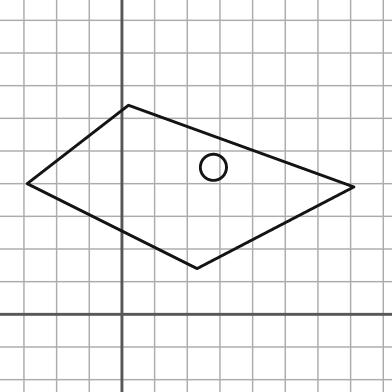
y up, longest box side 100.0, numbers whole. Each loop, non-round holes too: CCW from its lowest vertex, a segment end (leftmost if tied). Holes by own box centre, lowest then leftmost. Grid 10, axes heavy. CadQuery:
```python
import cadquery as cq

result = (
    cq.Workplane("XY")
    .moveTo(23.0, 14.0)
    .lineTo(71.0, 39.0)
    .lineTo(2.0, 64.0)
    .lineTo(-29.0, 40.0)
    .close()
    .moveTo(28.0, 45.0)
    .circle(4.0)
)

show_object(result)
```